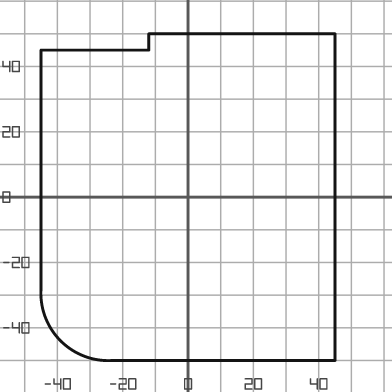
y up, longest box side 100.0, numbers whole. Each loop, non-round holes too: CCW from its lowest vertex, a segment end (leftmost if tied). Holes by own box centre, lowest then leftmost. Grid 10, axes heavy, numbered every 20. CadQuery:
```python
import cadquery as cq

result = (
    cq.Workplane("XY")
    .moveTo(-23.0, -50.0)
    .lineTo(45.0, -50.0)
    .lineTo(45.0, 50.0)
    .lineTo(-12.0, 50.0)
    .lineTo(-12.0, 45.0)
    .lineTo(-45.0, 45.0)
    .lineTo(-45.0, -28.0)
    .threePointArc((-39.0, -44.0), (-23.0, -50.0))
    .close()
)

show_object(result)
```